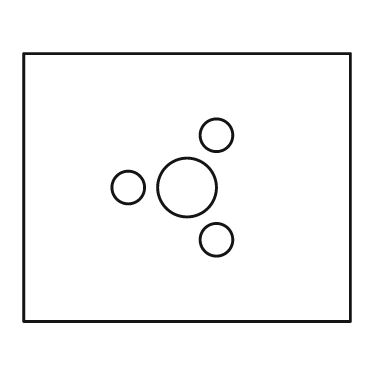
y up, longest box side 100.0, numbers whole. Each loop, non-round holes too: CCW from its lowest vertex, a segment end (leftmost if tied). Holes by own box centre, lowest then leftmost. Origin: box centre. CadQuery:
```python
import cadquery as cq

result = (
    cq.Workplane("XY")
    .moveTo(-50.0, -41.0)
    .lineTo(50.0, -41.0)
    .lineTo(50.0, 41.0)
    .lineTo(-50.0, 41.0)
    .close()
    .moveTo(9.0, -16.0)
    .circle(5.0)
    .moveTo(-18.0, 0.0)
    .circle(5.0)
    .moveTo(0.0, 0.0)
    .circle(9.0)
    .moveTo(9.0, 16.0)
    .circle(5.0)
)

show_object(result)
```